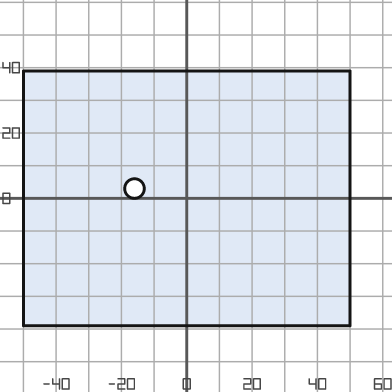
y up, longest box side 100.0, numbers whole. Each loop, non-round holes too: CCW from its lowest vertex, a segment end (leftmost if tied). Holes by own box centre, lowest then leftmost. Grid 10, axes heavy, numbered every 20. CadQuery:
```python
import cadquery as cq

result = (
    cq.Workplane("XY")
    .moveTo(-50.0, -39.0)
    .lineTo(50.0, -39.0)
    .lineTo(50.0, 39.0)
    .lineTo(-50.0, 39.0)
    .close()
    .moveTo(-16.0, 3.0)
    .circle(3.0)
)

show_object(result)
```